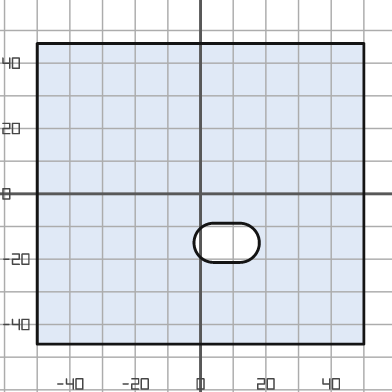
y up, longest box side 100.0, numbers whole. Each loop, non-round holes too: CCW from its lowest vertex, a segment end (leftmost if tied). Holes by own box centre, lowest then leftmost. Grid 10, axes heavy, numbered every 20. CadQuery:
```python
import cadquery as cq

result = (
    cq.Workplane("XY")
    .moveTo(-50.0, -46.0)
    .lineTo(50.0, -46.0)
    .lineTo(50.0, 46.0)
    .lineTo(-50.0, 46.0)
    .close()
    .moveTo(4.0, -21.0)
    .lineTo(12.0, -21.0)
    .threePointArc((18.0, -15.0), (12.0, -9.0))
    .lineTo(4.0, -9.0)
    .threePointArc((-2.0, -15.0), (4.0, -21.0))
    .close()
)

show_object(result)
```